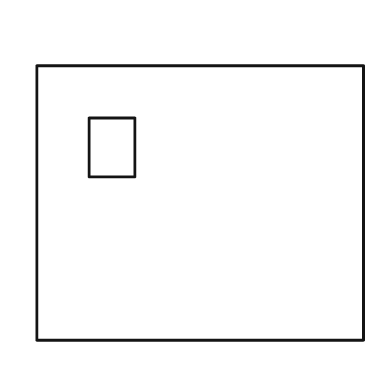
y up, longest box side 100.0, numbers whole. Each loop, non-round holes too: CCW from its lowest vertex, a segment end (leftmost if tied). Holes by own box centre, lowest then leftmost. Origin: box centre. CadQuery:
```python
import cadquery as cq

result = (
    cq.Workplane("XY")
    .moveTo(-50.0, -42.0)
    .lineTo(50.0, -42.0)
    .lineTo(50.0, 42.0)
    .lineTo(-50.0, 42.0)
    .close()
    .moveTo(-34.0, 8.0)
    .lineTo(-20.0, 8.0)
    .lineTo(-20.0, 26.0)
    .lineTo(-34.0, 26.0)
    .close()
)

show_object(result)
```